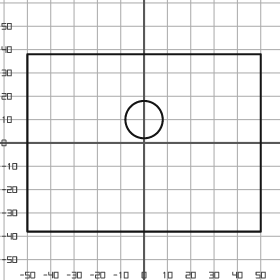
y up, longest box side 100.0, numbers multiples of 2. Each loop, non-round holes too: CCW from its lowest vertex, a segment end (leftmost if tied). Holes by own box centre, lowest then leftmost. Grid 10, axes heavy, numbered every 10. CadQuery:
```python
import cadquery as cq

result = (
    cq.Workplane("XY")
    .moveTo(-50.0, -38.0)
    .lineTo(50.0, -38.0)
    .lineTo(50.0, 38.0)
    .lineTo(-50.0, 38.0)
    .close()
    .moveTo(0.0, 10.0)
    .circle(8.0)
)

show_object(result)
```